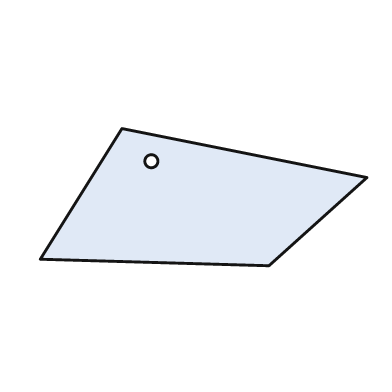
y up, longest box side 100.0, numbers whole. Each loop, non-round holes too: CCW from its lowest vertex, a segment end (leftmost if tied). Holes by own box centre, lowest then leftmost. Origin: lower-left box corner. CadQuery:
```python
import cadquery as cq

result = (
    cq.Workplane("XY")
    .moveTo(70.0, 0.0)
    .lineTo(100.0, 27.0)
    .lineTo(25.0, 42.0)
    .lineTo(0.0, 2.0)
    .close()
    .moveTo(34.0, 32.0)
    .circle(2.0)
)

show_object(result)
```